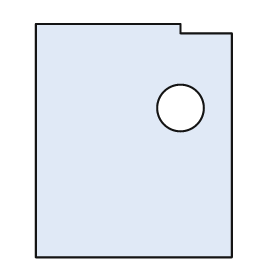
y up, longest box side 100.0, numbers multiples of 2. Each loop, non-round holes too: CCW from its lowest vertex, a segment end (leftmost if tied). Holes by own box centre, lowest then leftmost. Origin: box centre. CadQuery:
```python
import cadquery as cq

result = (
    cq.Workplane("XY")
    .moveTo(-42.0, -50.0)
    .lineTo(42.0, -50.0)
    .lineTo(42.0, 46.0)
    .lineTo(20.0, 46.0)
    .lineTo(20.0, 50.0)
    .lineTo(-42.0, 50.0)
    .close()
    .moveTo(20.0, 14.0)
    .circle(10.0)
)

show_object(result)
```